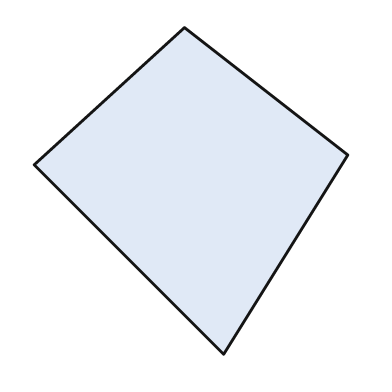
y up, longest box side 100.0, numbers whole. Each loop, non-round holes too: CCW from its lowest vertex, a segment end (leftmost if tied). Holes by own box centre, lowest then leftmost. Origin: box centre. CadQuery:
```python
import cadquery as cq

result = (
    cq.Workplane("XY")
    .moveTo(10.0, -50.0)
    .lineTo(48.0, 11.0)
    .lineTo(-2.0, 50.0)
    .lineTo(-48.0, 8.0)
    .close()
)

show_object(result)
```